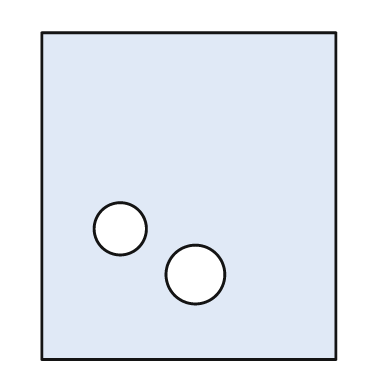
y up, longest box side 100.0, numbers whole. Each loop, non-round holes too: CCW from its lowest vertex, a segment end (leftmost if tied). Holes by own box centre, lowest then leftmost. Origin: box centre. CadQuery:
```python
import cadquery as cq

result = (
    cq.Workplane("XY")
    .moveTo(-45.0, -50.0)
    .lineTo(45.0, -50.0)
    .lineTo(45.0, 50.0)
    .lineTo(-45.0, 50.0)
    .close()
    .moveTo(2.0, -24.0)
    .circle(9.0)
    .moveTo(-21.0, -10.0)
    .circle(8.0)
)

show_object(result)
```